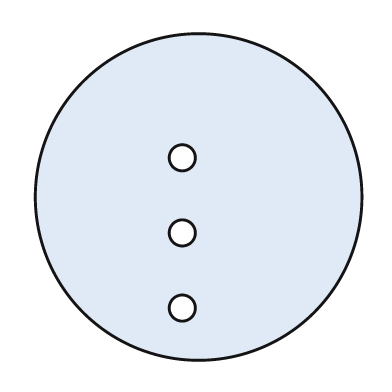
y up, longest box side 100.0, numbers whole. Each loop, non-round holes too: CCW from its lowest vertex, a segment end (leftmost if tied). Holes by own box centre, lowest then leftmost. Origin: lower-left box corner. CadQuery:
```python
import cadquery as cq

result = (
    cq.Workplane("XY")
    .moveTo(50.0, 50.0)
    .circle(50.0)
    .moveTo(45.0, 16.0)
    .circle(4.0)
    .moveTo(45.0, 39.0)
    .circle(4.0)
    .moveTo(45.0, 62.0)
    .circle(4.0)
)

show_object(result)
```